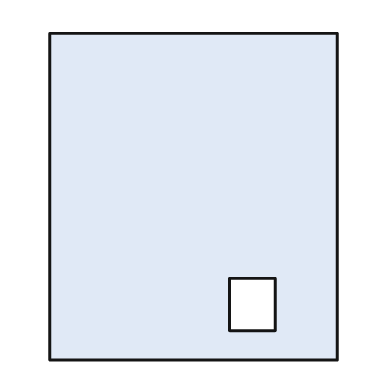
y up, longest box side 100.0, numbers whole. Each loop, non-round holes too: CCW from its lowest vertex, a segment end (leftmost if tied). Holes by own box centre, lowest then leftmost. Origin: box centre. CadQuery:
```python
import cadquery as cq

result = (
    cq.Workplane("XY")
    .moveTo(-44.0, -50.0)
    .lineTo(44.0, -50.0)
    .lineTo(44.0, 50.0)
    .lineTo(-44.0, 50.0)
    .close()
    .moveTo(11.0, -41.0)
    .lineTo(25.0, -41.0)
    .lineTo(25.0, -25.0)
    .lineTo(11.0, -25.0)
    .close()
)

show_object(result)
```